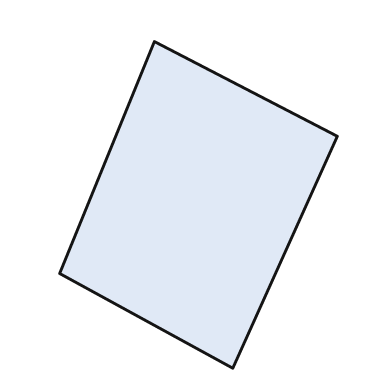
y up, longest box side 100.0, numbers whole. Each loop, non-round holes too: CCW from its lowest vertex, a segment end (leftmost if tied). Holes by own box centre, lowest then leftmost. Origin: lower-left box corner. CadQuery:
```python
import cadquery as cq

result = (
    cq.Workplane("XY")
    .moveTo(53.0, 0.0)
    .lineTo(85.0, 71.0)
    .lineTo(29.0, 100.0)
    .lineTo(0.0, 29.0)
    .close()
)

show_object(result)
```